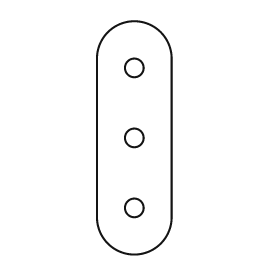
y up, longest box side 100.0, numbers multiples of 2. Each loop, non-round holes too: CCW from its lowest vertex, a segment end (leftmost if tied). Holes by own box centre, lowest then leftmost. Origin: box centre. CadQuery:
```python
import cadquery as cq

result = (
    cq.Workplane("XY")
    .moveTo(-16.0, -34.0)
    .threePointArc((0.0, -50.0), (16.0, -34.0))
    .lineTo(16.0, 34.0)
    .threePointArc((0.0, 50.0), (-16.0, 34.0))
    .close()
    .moveTo(0.0, -30.0)
    .circle(4.0)
    .moveTo(0.0, 0.0)
    .circle(4.0)
    .moveTo(0.0, 30.0)
    .circle(4.0)
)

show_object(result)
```